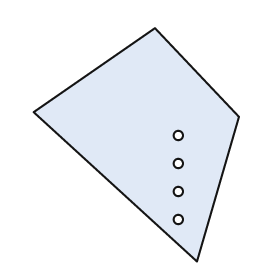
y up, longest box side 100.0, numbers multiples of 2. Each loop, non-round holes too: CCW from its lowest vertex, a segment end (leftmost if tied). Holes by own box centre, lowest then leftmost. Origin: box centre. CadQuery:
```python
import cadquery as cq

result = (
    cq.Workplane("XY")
    .moveTo(26.0, -50.0)
    .lineTo(44.0, 12.0)
    .lineTo(8.0, 50.0)
    .lineTo(-44.0, 14.0)
    .close()
    .moveTo(18.0, -32.0)
    .circle(2.0)
    .moveTo(18.0, -20.0)
    .circle(2.0)
    .moveTo(18.0, -8.0)
    .circle(2.0)
    .moveTo(18.0, 4.0)
    .circle(2.0)
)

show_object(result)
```